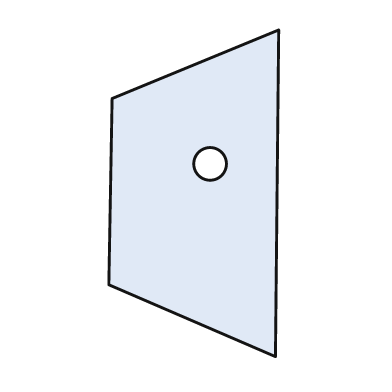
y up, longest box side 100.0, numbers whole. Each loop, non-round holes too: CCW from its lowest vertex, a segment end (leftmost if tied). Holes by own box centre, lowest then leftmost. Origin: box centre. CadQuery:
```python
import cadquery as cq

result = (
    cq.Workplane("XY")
    .moveTo(25.0, -50.0)
    .lineTo(26.0, 50.0)
    .lineTo(-25.0, 29.0)
    .lineTo(-26.0, -28.0)
    .close()
    .moveTo(5.0, 9.0)
    .circle(5.0)
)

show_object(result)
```